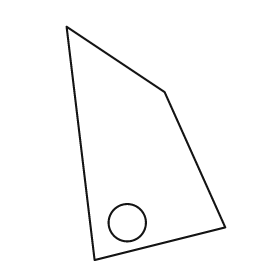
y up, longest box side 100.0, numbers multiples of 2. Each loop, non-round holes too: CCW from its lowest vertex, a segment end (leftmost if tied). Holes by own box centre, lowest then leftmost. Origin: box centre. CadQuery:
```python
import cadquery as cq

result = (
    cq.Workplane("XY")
    .moveTo(-22.0, -50.0)
    .lineTo(34.0, -36.0)
    .lineTo(8.0, 22.0)
    .lineTo(-34.0, 50.0)
    .close()
    .moveTo(-8.0, -34.0)
    .circle(8.0)
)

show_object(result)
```